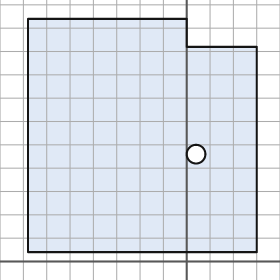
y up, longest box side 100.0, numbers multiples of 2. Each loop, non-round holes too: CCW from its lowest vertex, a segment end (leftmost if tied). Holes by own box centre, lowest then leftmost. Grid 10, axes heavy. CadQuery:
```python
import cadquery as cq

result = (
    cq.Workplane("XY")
    .moveTo(-68.0, 4.0)
    .lineTo(30.0, 4.0)
    .lineTo(30.0, 92.0)
    .lineTo(0.0, 92.0)
    .lineTo(0.0, 104.0)
    .lineTo(-68.0, 104.0)
    .close()
    .moveTo(4.0, 46.0)
    .circle(4.0)
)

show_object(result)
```